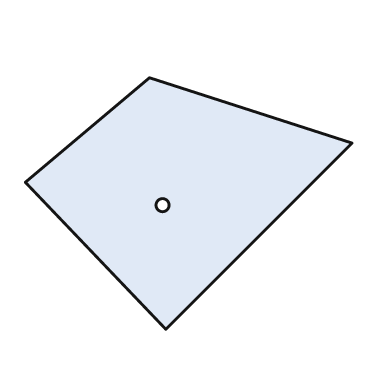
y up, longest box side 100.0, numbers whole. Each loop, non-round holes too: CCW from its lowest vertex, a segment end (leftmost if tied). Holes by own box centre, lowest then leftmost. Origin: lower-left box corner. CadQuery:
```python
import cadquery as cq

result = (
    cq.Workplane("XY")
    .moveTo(43.0, 0.0)
    .lineTo(100.0, 57.0)
    .lineTo(38.0, 77.0)
    .lineTo(0.0, 45.0)
    .close()
    .moveTo(42.0, 38.0)
    .circle(2.0)
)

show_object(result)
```